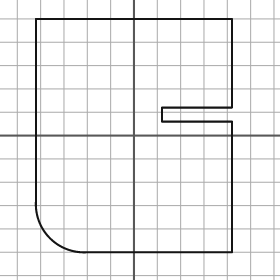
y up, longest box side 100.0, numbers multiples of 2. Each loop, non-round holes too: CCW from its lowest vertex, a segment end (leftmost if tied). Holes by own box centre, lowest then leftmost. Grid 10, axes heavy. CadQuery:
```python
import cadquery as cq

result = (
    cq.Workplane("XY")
    .moveTo(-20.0, -50.0)
    .lineTo(42.0, -50.0)
    .lineTo(42.0, 6.0)
    .lineTo(12.0, 6.0)
    .lineTo(12.0, 12.0)
    .lineTo(42.0, 12.0)
    .lineTo(42.0, 50.0)
    .lineTo(-42.0, 50.0)
    .lineTo(-42.0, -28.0)
    .threePointArc((-36.0, -44.0), (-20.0, -50.0))
    .close()
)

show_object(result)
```